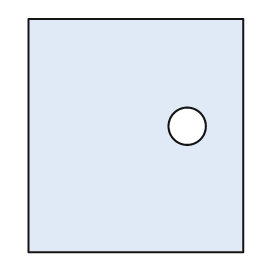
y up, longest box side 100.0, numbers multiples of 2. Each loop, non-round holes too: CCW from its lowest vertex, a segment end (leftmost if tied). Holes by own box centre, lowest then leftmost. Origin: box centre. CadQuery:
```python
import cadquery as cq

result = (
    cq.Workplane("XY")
    .moveTo(-46.0, -50.0)
    .lineTo(46.0, -50.0)
    .lineTo(46.0, 50.0)
    .lineTo(-46.0, 50.0)
    .close()
    .moveTo(22.0, 4.0)
    .circle(8.0)
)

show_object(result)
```